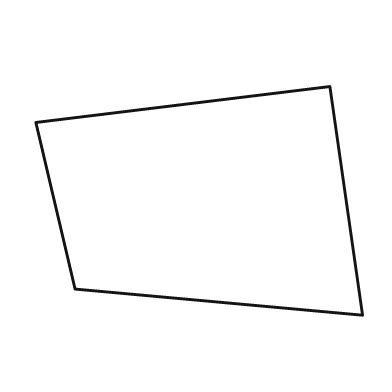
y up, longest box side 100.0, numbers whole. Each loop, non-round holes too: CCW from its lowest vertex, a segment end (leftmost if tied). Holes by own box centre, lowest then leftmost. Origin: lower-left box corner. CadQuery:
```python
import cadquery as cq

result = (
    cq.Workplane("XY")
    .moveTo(100.0, 0.0)
    .lineTo(90.0, 70.0)
    .lineTo(0.0, 59.0)
    .lineTo(12.0, 8.0)
    .close()
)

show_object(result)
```